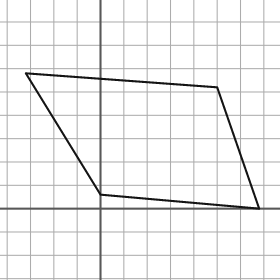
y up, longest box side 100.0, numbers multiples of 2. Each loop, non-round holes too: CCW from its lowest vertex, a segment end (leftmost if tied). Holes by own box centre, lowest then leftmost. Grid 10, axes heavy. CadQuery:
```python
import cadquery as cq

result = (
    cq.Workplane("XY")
    .moveTo(68.0, 0.0)
    .lineTo(50.0, 52.0)
    .lineTo(-32.0, 58.0)
    .lineTo(0.0, 6.0)
    .close()
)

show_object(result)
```